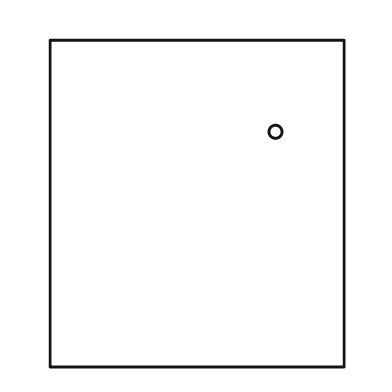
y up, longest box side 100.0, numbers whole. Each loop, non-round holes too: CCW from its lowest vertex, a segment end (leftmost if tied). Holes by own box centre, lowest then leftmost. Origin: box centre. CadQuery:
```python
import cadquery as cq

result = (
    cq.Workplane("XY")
    .moveTo(-45.0, -50.0)
    .lineTo(45.0, -50.0)
    .lineTo(45.0, 50.0)
    .lineTo(-45.0, 50.0)
    .close()
    .moveTo(24.0, 22.0)
    .circle(2.0)
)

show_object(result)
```